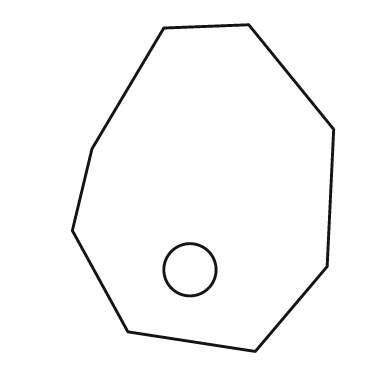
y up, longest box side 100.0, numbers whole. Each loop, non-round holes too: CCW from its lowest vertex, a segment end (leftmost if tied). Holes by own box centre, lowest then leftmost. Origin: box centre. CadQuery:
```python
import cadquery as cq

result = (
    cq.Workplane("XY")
    .moveTo(16.0, -50.0)
    .lineTo(38.0, -24.0)
    .lineTo(40.0, 18.0)
    .lineTo(14.0, 50.0)
    .lineTo(-12.0, 49.0)
    .lineTo(-34.0, 12.0)
    .lineTo(-40.0, -13.0)
    .lineTo(-23.0, -44.0)
    .close()
    .moveTo(-4.0, -25.0)
    .circle(8.0)
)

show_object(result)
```